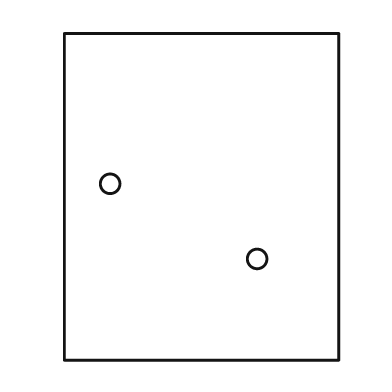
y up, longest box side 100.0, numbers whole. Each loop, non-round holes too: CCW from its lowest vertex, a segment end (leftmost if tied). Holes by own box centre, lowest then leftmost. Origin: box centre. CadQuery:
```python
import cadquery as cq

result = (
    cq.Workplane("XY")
    .moveTo(-42.0, -50.0)
    .lineTo(42.0, -50.0)
    .lineTo(42.0, 50.0)
    .lineTo(-42.0, 50.0)
    .close()
    .moveTo(17.0, -19.0)
    .circle(3.0)
    .moveTo(-28.0, 4.0)
    .circle(3.0)
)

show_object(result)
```